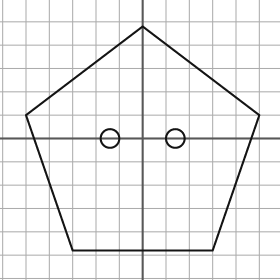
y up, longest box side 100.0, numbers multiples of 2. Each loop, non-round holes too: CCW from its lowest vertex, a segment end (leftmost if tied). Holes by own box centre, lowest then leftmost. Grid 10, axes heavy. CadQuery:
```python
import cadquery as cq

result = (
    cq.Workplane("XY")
    .moveTo(-30.0, -48.0)
    .lineTo(30.0, -48.0)
    .lineTo(50.0, 10.0)
    .lineTo(0.0, 48.0)
    .lineTo(-50.0, 10.0)
    .close()
    .moveTo(-14.0, 0.0)
    .circle(4.0)
    .moveTo(14.0, 0.0)
    .circle(4.0)
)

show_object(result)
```